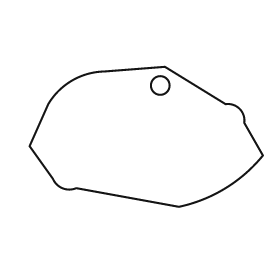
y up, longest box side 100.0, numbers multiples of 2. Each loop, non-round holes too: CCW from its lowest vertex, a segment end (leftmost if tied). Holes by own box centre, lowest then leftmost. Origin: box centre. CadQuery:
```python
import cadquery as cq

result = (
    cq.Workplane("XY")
    .moveTo(14.0, -30.0)
    .threePointArc((34.0, -22.0), (50.0, -8.0))
    .lineTo(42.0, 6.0)
    .threePointArc((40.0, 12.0), (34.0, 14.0))
    .lineTo(8.0, 30.0)
    .lineTo(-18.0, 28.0)
    .threePointArc((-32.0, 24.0), (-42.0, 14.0))
    .lineTo(-50.0, -4.0)
    .lineTo(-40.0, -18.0)
    .threePointArc((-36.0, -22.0), (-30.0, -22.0))
    .close()
    .moveTo(6.0, 22.0)
    .circle(4.0)
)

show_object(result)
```